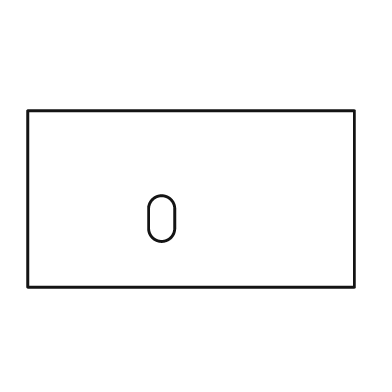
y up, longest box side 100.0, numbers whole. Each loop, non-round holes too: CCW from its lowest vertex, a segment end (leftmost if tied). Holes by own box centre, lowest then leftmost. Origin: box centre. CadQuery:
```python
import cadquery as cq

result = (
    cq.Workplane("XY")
    .moveTo(-50.0, -27.0)
    .lineTo(50.0, -27.0)
    .lineTo(50.0, 27.0)
    .lineTo(-50.0, 27.0)
    .close()
    .moveTo(-13.0, -9.0)
    .threePointArc((-9.0, -13.0), (-5.0, -9.0))
    .lineTo(-5.0, -3.0)
    .threePointArc((-9.0, 1.0), (-13.0, -3.0))
    .close()
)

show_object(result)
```